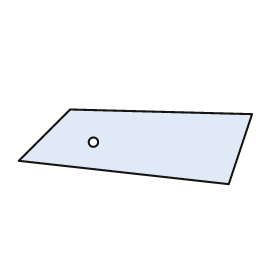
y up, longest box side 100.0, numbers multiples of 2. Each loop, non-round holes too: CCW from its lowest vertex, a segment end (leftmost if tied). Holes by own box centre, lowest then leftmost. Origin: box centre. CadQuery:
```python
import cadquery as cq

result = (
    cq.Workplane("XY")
    .moveTo(40.0, -16.0)
    .lineTo(50.0, 14.0)
    .lineTo(-28.0, 16.0)
    .lineTo(-50.0, -6.0)
    .close()
    .moveTo(-18.0, 2.0)
    .circle(2.0)
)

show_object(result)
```